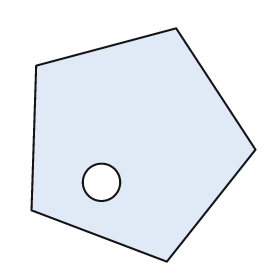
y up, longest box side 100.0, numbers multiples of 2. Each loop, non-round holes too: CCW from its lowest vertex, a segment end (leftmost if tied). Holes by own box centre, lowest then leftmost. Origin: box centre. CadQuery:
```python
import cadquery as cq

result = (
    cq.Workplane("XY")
    .moveTo(10.0, -50.0)
    .lineTo(48.0, -2.0)
    .lineTo(14.0, 50.0)
    .lineTo(-46.0, 34.0)
    .lineTo(-48.0, -28.0)
    .close()
    .moveTo(-18.0, -16.0)
    .circle(8.0)
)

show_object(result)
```